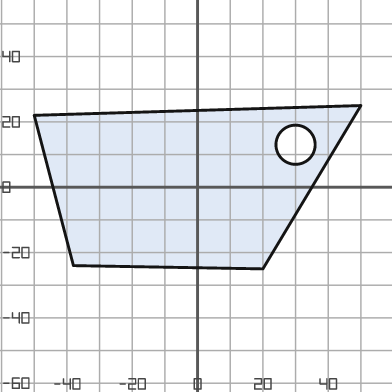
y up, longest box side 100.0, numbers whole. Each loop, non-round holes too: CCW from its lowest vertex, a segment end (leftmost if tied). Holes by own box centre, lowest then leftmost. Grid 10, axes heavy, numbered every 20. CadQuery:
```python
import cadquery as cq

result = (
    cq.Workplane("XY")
    .moveTo(20.0, -25.0)
    .lineTo(50.0, 25.0)
    .lineTo(-50.0, 22.0)
    .lineTo(-38.0, -24.0)
    .close()
    .moveTo(30.0, 13.0)
    .circle(6.0)
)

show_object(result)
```